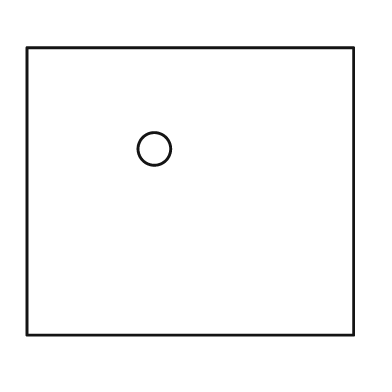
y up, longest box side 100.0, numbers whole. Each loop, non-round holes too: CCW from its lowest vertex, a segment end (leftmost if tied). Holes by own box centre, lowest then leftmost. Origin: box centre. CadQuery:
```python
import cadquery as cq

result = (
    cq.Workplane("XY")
    .moveTo(-50.0, -44.0)
    .lineTo(50.0, -44.0)
    .lineTo(50.0, 44.0)
    .lineTo(-50.0, 44.0)
    .close()
    .moveTo(-11.0, 13.0)
    .circle(5.0)
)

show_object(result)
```